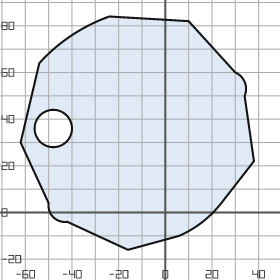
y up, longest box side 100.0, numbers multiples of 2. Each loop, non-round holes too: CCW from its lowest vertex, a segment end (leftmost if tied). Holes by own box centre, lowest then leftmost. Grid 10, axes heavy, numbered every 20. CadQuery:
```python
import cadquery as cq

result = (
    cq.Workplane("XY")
    .moveTo(-16.0, -16.0)
    .lineTo(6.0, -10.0)
    .threePointArc((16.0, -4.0), (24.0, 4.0))
    .lineTo(38.0, 22.0)
    .lineTo(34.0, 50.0)
    .threePointArc((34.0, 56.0), (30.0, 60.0))
    .lineTo(10.0, 82.0)
    .lineTo(-24.0, 84.0)
    .threePointArc((-40.0, 76.0), (-54.0, 64.0))
    .lineTo(-62.0, 30.0)
    .lineTo(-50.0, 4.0)
    .threePointArc((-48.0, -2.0), (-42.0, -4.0))
    .close()
    .moveTo(-48.0, 36.0)
    .circle(8.0)
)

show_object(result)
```